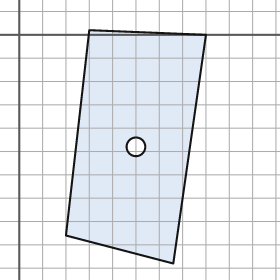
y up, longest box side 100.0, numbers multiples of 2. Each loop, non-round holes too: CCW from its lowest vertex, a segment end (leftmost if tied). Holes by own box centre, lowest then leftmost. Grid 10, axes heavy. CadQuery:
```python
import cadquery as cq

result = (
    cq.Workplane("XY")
    .moveTo(66.0, -98.0)
    .lineTo(80.0, 0.0)
    .lineTo(30.0, 2.0)
    .lineTo(20.0, -86.0)
    .close()
    .moveTo(50.0, -48.0)
    .circle(4.0)
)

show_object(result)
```